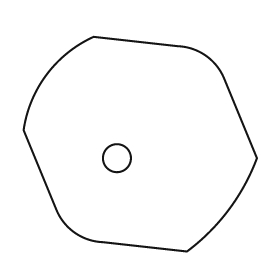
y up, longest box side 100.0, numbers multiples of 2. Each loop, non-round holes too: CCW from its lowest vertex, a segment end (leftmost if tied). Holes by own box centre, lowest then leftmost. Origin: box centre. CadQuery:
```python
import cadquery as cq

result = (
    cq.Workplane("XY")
    .moveTo(20.0, -46.0)
    .threePointArc((38.0, -28.0), (50.0, -6.0))
    .lineTo(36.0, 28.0)
    .threePointArc((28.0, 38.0), (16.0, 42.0))
    .lineTo(-20.0, 46.0)
    .threePointArc((-40.0, 30.0), (-50.0, 6.0))
    .lineTo(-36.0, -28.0)
    .threePointArc((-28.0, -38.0), (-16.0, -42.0))
    .close()
    .moveTo(-10.0, -6.0)
    .circle(6.0)
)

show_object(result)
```